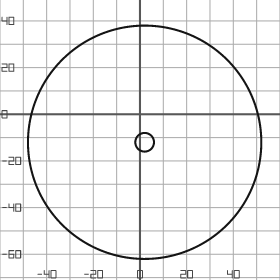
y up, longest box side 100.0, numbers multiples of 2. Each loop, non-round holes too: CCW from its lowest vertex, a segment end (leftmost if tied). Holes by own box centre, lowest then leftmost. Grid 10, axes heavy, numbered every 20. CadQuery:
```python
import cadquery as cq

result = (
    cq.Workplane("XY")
    .moveTo(2.0, -12.0)
    .circle(50.0)
    .moveTo(2.0, -12.0)
    .circle(4.0)
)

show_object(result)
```